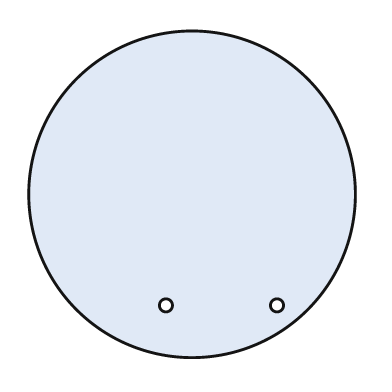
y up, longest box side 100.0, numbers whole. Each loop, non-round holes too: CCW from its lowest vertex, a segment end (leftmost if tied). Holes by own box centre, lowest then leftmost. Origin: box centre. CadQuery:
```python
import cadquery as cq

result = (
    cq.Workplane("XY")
    .moveTo(0.0, 0.0)
    .circle(50.0)
    .moveTo(-8.0, -34.0)
    .circle(2.0)
    .moveTo(26.0, -34.0)
    .circle(2.0)
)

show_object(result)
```